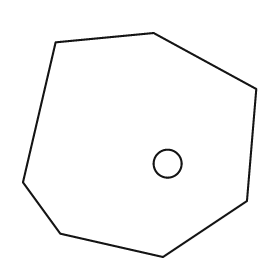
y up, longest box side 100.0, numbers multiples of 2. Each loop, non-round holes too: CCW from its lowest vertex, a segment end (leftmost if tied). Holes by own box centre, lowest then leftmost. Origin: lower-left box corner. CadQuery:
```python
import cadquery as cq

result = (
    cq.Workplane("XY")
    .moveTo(60.0, 0.0)
    .lineTo(96.0, 24.0)
    .lineTo(100.0, 72.0)
    .lineTo(56.0, 96.0)
    .lineTo(14.0, 92.0)
    .lineTo(0.0, 32.0)
    .lineTo(16.0, 10.0)
    .close()
    .moveTo(62.0, 40.0)
    .circle(6.0)
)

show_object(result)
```